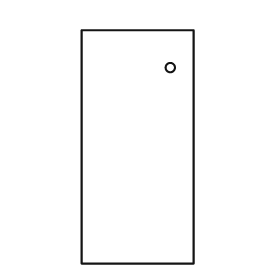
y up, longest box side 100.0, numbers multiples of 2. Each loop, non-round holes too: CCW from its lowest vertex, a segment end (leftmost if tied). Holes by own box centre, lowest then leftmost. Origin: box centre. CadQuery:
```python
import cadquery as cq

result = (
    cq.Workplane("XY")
    .moveTo(-24.0, -50.0)
    .lineTo(24.0, -50.0)
    .lineTo(24.0, 50.0)
    .lineTo(-24.0, 50.0)
    .close()
    .moveTo(14.0, 34.0)
    .circle(2.0)
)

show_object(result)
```